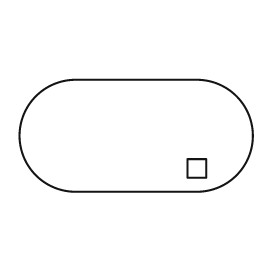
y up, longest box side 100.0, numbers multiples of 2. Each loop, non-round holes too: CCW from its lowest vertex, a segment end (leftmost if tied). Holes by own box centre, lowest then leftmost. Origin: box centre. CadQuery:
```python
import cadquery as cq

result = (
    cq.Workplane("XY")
    .moveTo(-26.0, -24.0)
    .lineTo(26.0, -24.0)
    .threePointArc((50.0, 0.0), (26.0, 24.0))
    .lineTo(-26.0, 24.0)
    .threePointArc((-50.0, 0.0), (-26.0, -24.0))
    .close()
    .moveTo(22.0, -18.0)
    .lineTo(30.0, -18.0)
    .lineTo(30.0, -10.0)
    .lineTo(22.0, -10.0)
    .close()
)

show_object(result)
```